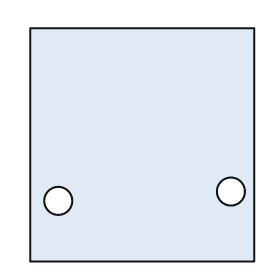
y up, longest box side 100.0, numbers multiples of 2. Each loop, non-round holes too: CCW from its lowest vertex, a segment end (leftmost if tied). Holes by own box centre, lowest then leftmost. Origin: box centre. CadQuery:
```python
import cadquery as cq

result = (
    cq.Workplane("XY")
    .moveTo(-48.0, -50.0)
    .lineTo(48.0, -50.0)
    .lineTo(48.0, 50.0)
    .lineTo(-48.0, 50.0)
    .close()
    .moveTo(-36.0, -24.0)
    .circle(6.0)
    .moveTo(38.0, -20.0)
    .circle(6.0)
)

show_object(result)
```